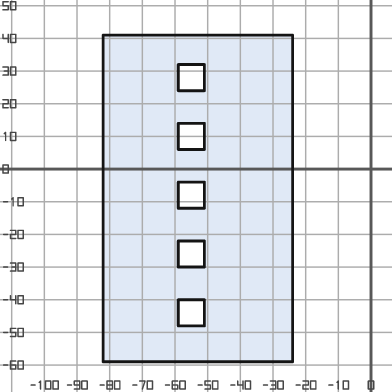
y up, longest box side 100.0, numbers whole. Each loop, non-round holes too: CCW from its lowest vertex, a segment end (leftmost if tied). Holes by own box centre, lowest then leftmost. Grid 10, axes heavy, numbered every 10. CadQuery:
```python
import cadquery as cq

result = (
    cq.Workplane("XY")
    .moveTo(-82.0, -59.0)
    .lineTo(-24.0, -59.0)
    .lineTo(-24.0, 41.0)
    .lineTo(-82.0, 41.0)
    .close()
    .moveTo(-59.0, -48.0)
    .lineTo(-51.0, -48.0)
    .lineTo(-51.0, -40.0)
    .lineTo(-59.0, -40.0)
    .close()
    .moveTo(-59.0, -30.0)
    .lineTo(-51.0, -30.0)
    .lineTo(-51.0, -22.0)
    .lineTo(-59.0, -22.0)
    .close()
    .moveTo(-59.0, -12.0)
    .lineTo(-51.0, -12.0)
    .lineTo(-51.0, -4.0)
    .lineTo(-59.0, -4.0)
    .close()
    .moveTo(-59.0, 6.0)
    .lineTo(-51.0, 6.0)
    .lineTo(-51.0, 14.0)
    .lineTo(-59.0, 14.0)
    .close()
    .moveTo(-59.0, 24.0)
    .lineTo(-51.0, 24.0)
    .lineTo(-51.0, 32.0)
    .lineTo(-59.0, 32.0)
    .close()
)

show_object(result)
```